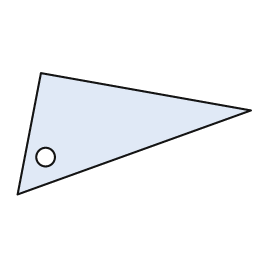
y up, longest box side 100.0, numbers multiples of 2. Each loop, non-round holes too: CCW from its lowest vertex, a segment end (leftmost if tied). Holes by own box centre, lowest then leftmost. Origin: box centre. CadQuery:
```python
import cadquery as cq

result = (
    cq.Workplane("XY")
    .moveTo(-50.0, -26.0)
    .lineTo(50.0, 10.0)
    .lineTo(-40.0, 26.0)
    .close()
    .moveTo(-38.0, -10.0)
    .circle(4.0)
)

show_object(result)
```